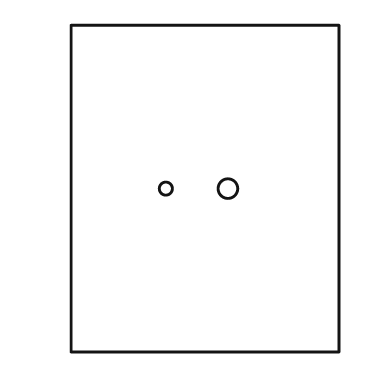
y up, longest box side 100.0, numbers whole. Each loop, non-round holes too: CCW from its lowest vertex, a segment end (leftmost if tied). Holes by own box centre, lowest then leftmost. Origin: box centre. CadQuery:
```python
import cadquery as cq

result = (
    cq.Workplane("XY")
    .moveTo(-41.0, -50.0)
    .lineTo(41.0, -50.0)
    .lineTo(41.0, 50.0)
    .lineTo(-41.0, 50.0)
    .close()
    .moveTo(-12.0, 0.0)
    .circle(2.0)
    .moveTo(7.0, 0.0)
    .circle(3.0)
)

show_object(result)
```